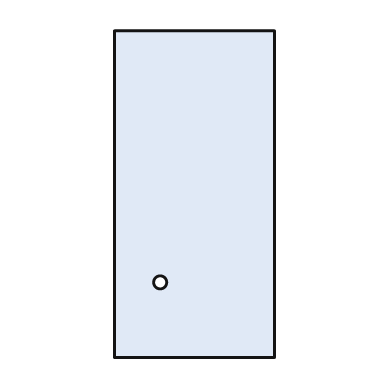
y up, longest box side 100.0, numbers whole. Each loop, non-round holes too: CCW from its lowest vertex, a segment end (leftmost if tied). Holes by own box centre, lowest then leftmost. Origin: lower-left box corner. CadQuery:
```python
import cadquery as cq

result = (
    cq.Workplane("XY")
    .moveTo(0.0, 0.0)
    .lineTo(49.0, 0.0)
    .lineTo(49.0, 100.0)
    .lineTo(0.0, 100.0)
    .close()
    .moveTo(14.0, 23.0)
    .circle(2.0)
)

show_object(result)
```